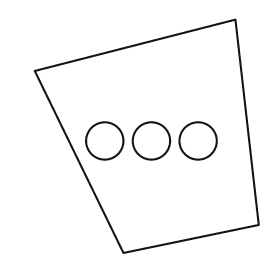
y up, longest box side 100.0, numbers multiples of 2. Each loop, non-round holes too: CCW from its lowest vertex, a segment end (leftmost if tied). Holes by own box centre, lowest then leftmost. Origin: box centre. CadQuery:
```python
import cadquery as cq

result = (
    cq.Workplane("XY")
    .moveTo(-10.0, -50.0)
    .lineTo(48.0, -38.0)
    .lineTo(38.0, 50.0)
    .lineTo(-48.0, 28.0)
    .close()
    .moveTo(-18.0, -2.0)
    .circle(8.0)
    .moveTo(2.0, -2.0)
    .circle(8.0)
    .moveTo(22.0, -2.0)
    .circle(8.0)
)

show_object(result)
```